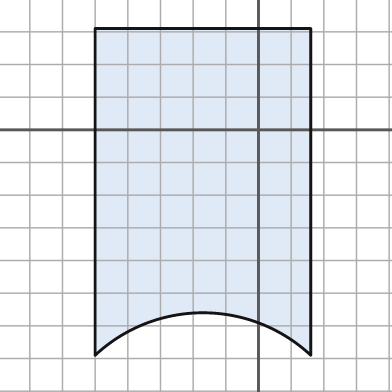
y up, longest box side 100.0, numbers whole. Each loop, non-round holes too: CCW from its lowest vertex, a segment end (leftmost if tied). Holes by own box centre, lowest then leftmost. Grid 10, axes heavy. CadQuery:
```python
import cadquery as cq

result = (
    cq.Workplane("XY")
    .moveTo(-50.0, -69.0)
    .threePointArc((-17.0, -56.0), (16.0, -69.0))
    .lineTo(16.0, 31.0)
    .lineTo(-50.0, 31.0)
    .close()
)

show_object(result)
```